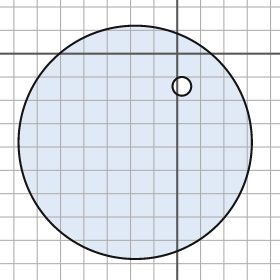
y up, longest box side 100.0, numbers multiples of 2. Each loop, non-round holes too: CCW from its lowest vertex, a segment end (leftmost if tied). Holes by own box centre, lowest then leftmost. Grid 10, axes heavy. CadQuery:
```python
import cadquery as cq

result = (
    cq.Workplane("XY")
    .moveTo(-18.0, -38.0)
    .circle(50.0)
    .moveTo(2.0, -14.0)
    .circle(4.0)
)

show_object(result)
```